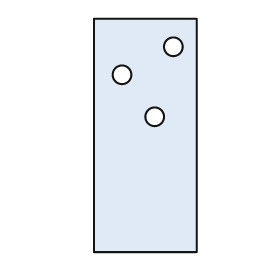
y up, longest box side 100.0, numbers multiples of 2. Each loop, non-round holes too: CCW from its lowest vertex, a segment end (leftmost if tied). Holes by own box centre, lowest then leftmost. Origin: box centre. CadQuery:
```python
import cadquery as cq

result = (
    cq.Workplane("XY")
    .moveTo(-22.0, -50.0)
    .lineTo(22.0, -50.0)
    .lineTo(22.0, 50.0)
    .lineTo(-22.0, 50.0)
    .close()
    .moveTo(4.0, 8.0)
    .circle(4.0)
    .moveTo(-10.0, 26.0)
    .circle(4.0)
    .moveTo(12.0, 38.0)
    .circle(4.0)
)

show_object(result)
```